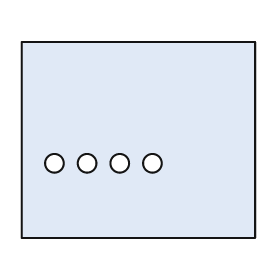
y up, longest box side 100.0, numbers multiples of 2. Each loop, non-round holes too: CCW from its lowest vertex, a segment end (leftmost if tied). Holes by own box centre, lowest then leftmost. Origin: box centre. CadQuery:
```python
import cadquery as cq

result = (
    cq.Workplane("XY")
    .moveTo(-50.0, -42.0)
    .lineTo(50.0, -42.0)
    .lineTo(50.0, 42.0)
    .lineTo(-50.0, 42.0)
    .close()
    .moveTo(-36.0, -10.0)
    .circle(4.0)
    .moveTo(-22.0, -10.0)
    .circle(4.0)
    .moveTo(-8.0, -10.0)
    .circle(4.0)
    .moveTo(6.0, -10.0)
    .circle(4.0)
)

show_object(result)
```